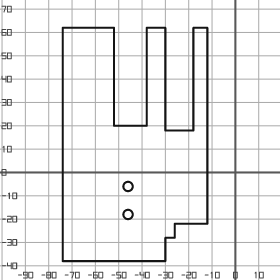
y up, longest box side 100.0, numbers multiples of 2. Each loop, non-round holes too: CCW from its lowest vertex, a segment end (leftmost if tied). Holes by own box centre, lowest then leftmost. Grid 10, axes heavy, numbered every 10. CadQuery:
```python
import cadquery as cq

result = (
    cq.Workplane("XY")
    .moveTo(-74.0, -38.0)
    .lineTo(-30.0, -38.0)
    .lineTo(-30.0, -28.0)
    .lineTo(-26.0, -28.0)
    .lineTo(-26.0, -22.0)
    .lineTo(-12.0, -22.0)
    .lineTo(-12.0, 62.0)
    .lineTo(-18.0, 62.0)
    .lineTo(-18.0, 18.0)
    .lineTo(-30.0, 18.0)
    .lineTo(-30.0, 62.0)
    .lineTo(-38.0, 62.0)
    .lineTo(-38.0, 20.0)
    .lineTo(-52.0, 20.0)
    .lineTo(-52.0, 62.0)
    .lineTo(-74.0, 62.0)
    .close()
    .moveTo(-46.0, -18.0)
    .circle(2.0)
    .moveTo(-46.0, -6.0)
    .circle(2.0)
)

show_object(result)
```